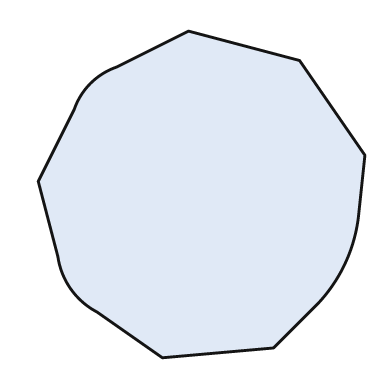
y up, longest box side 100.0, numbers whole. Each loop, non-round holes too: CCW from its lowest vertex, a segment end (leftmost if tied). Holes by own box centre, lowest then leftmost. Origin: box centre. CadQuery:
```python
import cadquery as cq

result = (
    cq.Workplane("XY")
    .moveTo(-12.0, -50.0)
    .lineTo(22.0, -47.0)
    .lineTo(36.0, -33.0)
    .threePointArc((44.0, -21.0), (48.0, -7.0))
    .lineTo(50.0, 12.0)
    .lineTo(30.0, 41.0)
    .lineTo(-4.0, 50.0)
    .lineTo(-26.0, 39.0)
    .threePointArc((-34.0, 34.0), (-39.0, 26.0))
    .lineTo(-50.0, 4.0)
    .lineTo(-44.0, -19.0)
    .threePointArc((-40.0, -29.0), (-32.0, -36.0))
    .close()
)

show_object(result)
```